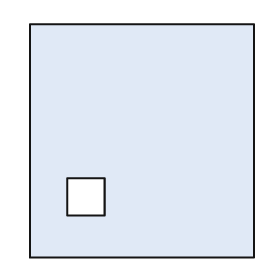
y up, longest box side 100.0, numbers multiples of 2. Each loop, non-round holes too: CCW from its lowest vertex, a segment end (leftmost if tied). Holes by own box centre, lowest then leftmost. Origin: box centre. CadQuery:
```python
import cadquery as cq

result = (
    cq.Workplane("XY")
    .moveTo(-48.0, -50.0)
    .lineTo(48.0, -50.0)
    .lineTo(48.0, 50.0)
    .lineTo(-48.0, 50.0)
    .close()
    .moveTo(-32.0, -32.0)
    .lineTo(-16.0, -32.0)
    .lineTo(-16.0, -16.0)
    .lineTo(-32.0, -16.0)
    .close()
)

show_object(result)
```